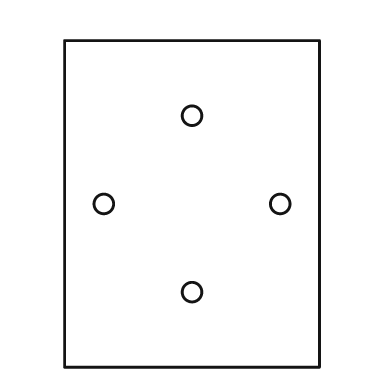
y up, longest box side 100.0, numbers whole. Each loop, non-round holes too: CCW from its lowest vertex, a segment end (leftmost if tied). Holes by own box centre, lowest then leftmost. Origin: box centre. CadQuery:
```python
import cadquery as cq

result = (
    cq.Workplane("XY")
    .moveTo(-39.0, -50.0)
    .lineTo(39.0, -50.0)
    .lineTo(39.0, 50.0)
    .lineTo(-39.0, 50.0)
    .close()
    .moveTo(0.0, -27.0)
    .circle(3.0)
    .moveTo(-27.0, 0.0)
    .circle(3.0)
    .moveTo(27.0, 0.0)
    .circle(3.0)
    .moveTo(0.0, 27.0)
    .circle(3.0)
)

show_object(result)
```